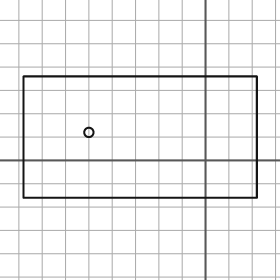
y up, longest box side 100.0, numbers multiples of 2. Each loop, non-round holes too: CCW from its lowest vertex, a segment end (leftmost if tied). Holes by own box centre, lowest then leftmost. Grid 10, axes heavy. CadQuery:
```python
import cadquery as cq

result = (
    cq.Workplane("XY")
    .moveTo(-78.0, -16.0)
    .lineTo(22.0, -16.0)
    .lineTo(22.0, 36.0)
    .lineTo(-78.0, 36.0)
    .close()
    .moveTo(-50.0, 12.0)
    .circle(2.0)
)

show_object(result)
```